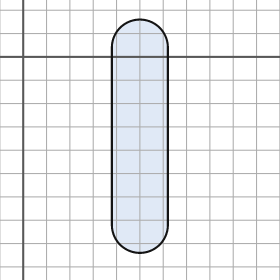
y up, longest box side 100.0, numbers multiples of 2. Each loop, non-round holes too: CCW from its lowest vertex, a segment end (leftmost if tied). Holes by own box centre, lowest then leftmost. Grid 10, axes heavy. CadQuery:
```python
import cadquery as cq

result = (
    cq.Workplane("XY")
    .moveTo(38.0, -72.0)
    .threePointArc((50.0, -84.0), (62.0, -72.0))
    .lineTo(62.0, 4.0)
    .threePointArc((50.0, 16.0), (38.0, 4.0))
    .close()
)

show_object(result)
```